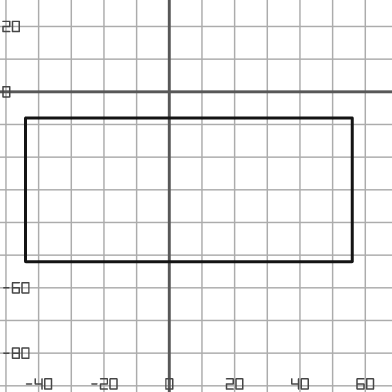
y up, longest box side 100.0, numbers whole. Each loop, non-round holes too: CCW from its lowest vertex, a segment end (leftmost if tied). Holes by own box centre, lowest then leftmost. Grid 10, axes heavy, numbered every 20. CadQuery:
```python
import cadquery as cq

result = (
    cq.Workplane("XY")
    .moveTo(-44.0, -52.0)
    .lineTo(56.0, -52.0)
    .lineTo(56.0, -8.0)
    .lineTo(-44.0, -8.0)
    .close()
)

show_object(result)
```